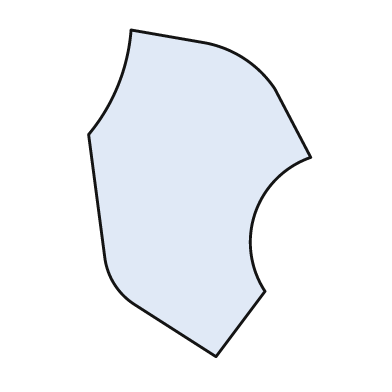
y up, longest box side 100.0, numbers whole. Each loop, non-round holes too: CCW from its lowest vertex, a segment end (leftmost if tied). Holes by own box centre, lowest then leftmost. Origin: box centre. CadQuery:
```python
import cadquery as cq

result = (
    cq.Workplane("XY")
    .moveTo(5.0, -50.0)
    .lineTo(20.0, -30.0)
    .threePointArc((17.0, -6.0), (34.0, 11.0))
    .lineTo(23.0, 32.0)
    .threePointArc((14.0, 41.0), (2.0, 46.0))
    .lineTo(-21.0, 50.0)
    .threePointArc((-25.0, 33.0), (-34.0, 18.0))
    .lineTo(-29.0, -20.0)
    .threePointArc((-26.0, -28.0), (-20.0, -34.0))
    .close()
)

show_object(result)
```